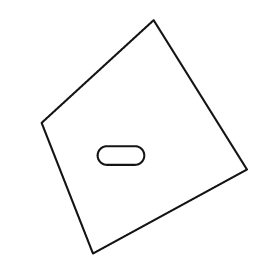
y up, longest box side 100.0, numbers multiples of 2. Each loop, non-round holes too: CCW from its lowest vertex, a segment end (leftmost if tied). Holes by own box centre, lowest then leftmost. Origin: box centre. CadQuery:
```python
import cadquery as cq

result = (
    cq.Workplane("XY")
    .moveTo(-22.0, -50.0)
    .lineTo(44.0, -14.0)
    .lineTo(4.0, 50.0)
    .lineTo(-44.0, 6.0)
    .close()
    .moveTo(-16.0, -12.0)
    .lineTo(-4.0, -12.0)
    .threePointArc((0.0, -8.0), (-4.0, -4.0))
    .lineTo(-16.0, -4.0)
    .threePointArc((-20.0, -8.0), (-16.0, -12.0))
    .close()
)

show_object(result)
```